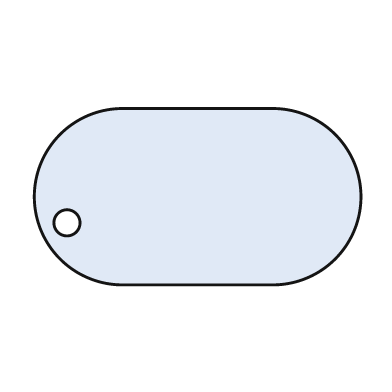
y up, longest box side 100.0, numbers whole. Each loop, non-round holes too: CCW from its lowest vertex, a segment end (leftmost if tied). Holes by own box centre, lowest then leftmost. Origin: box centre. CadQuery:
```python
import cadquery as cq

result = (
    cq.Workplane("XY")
    .moveTo(-23.0, -27.0)
    .lineTo(23.0, -27.0)
    .threePointArc((50.0, 0.0), (23.0, 27.0))
    .lineTo(-23.0, 27.0)
    .threePointArc((-50.0, 0.0), (-23.0, -27.0))
    .close()
    .moveTo(-40.0, -8.0)
    .circle(4.0)
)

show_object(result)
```